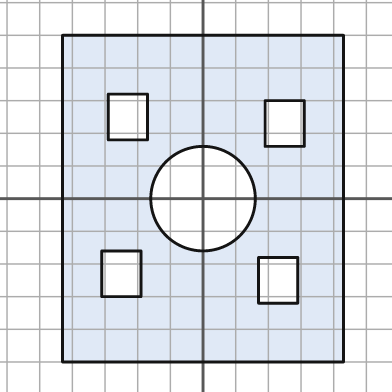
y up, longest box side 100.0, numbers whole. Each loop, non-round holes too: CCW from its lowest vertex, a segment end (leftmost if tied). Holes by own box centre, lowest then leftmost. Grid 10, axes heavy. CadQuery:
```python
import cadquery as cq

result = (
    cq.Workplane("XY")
    .moveTo(-43.0, -50.0)
    .lineTo(43.0, -50.0)
    .lineTo(43.0, 50.0)
    .lineTo(-43.0, 50.0)
    .close()
    .moveTo(17.0, -32.0)
    .lineTo(29.0, -32.0)
    .lineTo(29.0, -18.0)
    .lineTo(17.0, -18.0)
    .close()
    .moveTo(-31.0, -30.0)
    .lineTo(-19.0, -30.0)
    .lineTo(-19.0, -16.0)
    .lineTo(-31.0, -16.0)
    .close()
    .moveTo(0.0, 0.0)
    .circle(16.0)
    .moveTo(19.0, 16.0)
    .lineTo(31.0, 16.0)
    .lineTo(31.0, 30.0)
    .lineTo(19.0, 30.0)
    .close()
    .moveTo(-29.0, 18.0)
    .lineTo(-17.0, 18.0)
    .lineTo(-17.0, 32.0)
    .lineTo(-29.0, 32.0)
    .close()
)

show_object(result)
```